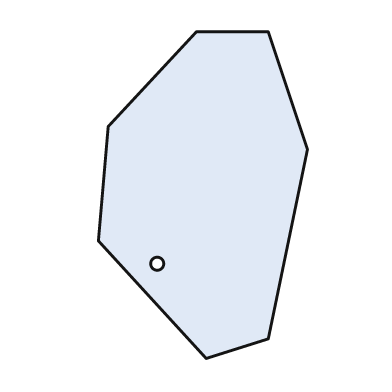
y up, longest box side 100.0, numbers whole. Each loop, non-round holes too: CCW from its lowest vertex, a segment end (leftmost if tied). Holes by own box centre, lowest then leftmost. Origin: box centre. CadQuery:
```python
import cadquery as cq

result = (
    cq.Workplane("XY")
    .moveTo(1.0, -50.0)
    .lineTo(20.0, -44.0)
    .lineTo(32.0, 14.0)
    .lineTo(20.0, 50.0)
    .lineTo(-2.0, 50.0)
    .lineTo(-29.0, 21.0)
    .lineTo(-32.0, -14.0)
    .close()
    .moveTo(-14.0, -21.0)
    .circle(2.0)
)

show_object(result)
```